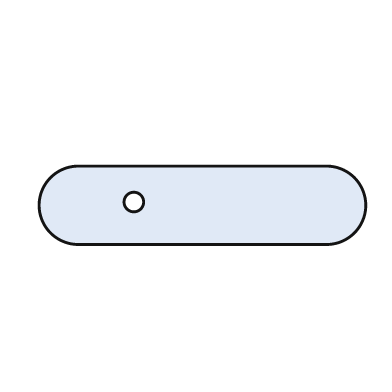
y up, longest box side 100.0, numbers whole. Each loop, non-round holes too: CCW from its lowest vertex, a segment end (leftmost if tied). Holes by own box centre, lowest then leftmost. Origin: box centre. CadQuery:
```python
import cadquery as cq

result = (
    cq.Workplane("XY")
    .moveTo(-38.0, -12.0)
    .lineTo(38.0, -12.0)
    .threePointArc((50.0, 0.0), (38.0, 12.0))
    .lineTo(-38.0, 12.0)
    .threePointArc((-50.0, 0.0), (-38.0, -12.0))
    .close()
    .moveTo(-21.0, 1.0)
    .circle(3.0)
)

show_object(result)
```